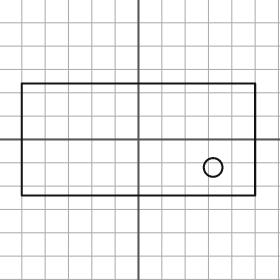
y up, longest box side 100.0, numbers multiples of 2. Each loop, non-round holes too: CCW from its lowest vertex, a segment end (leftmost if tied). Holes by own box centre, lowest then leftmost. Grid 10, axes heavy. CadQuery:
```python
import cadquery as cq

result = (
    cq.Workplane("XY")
    .moveTo(-50.0, -24.0)
    .lineTo(50.0, -24.0)
    .lineTo(50.0, 24.0)
    .lineTo(-50.0, 24.0)
    .close()
    .moveTo(32.0, -12.0)
    .circle(4.0)
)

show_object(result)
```